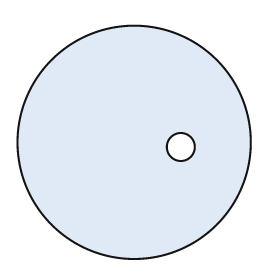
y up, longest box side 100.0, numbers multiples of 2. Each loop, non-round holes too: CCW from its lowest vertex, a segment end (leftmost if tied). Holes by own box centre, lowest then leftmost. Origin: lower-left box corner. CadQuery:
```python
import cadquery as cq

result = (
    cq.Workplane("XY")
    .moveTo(50.0, 50.0)
    .circle(50.0)
    .moveTo(70.0, 48.0)
    .circle(6.0)
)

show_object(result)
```